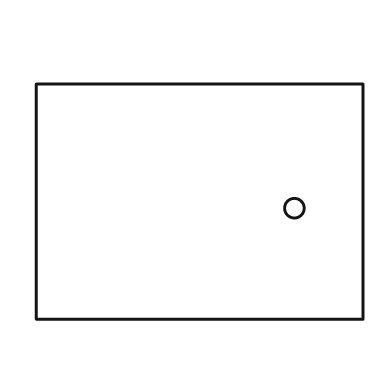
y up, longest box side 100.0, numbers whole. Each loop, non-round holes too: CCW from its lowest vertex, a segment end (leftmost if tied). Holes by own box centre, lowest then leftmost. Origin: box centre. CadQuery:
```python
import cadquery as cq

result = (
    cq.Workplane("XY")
    .moveTo(-50.0, -36.0)
    .lineTo(50.0, -36.0)
    .lineTo(50.0, 36.0)
    .lineTo(-50.0, 36.0)
    .close()
    .moveTo(29.0, -2.0)
    .circle(3.0)
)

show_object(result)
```